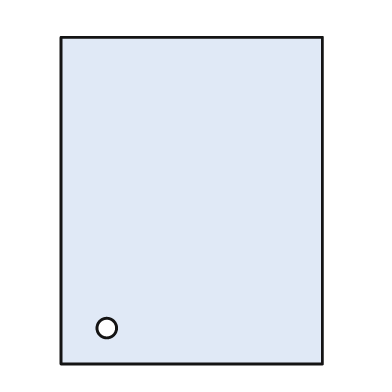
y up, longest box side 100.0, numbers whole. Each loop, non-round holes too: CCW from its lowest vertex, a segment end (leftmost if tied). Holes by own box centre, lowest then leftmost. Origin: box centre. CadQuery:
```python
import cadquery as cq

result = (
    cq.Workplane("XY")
    .moveTo(-40.0, -50.0)
    .lineTo(40.0, -50.0)
    .lineTo(40.0, 50.0)
    .lineTo(-40.0, 50.0)
    .close()
    .moveTo(-26.0, -39.0)
    .circle(3.0)
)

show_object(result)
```